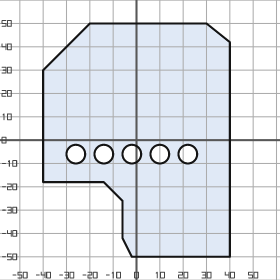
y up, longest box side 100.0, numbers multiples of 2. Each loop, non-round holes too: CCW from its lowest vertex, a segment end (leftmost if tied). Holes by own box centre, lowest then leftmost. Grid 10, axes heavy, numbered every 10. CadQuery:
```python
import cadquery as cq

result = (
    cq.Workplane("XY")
    .moveTo(-2.0, -50.0)
    .lineTo(40.0, -50.0)
    .lineTo(40.0, 42.0)
    .lineTo(30.0, 50.0)
    .lineTo(-20.0, 50.0)
    .lineTo(-40.0, 30.0)
    .lineTo(-40.0, -18.0)
    .lineTo(-14.0, -18.0)
    .lineTo(-6.0, -26.0)
    .lineTo(-6.0, -42.0)
    .close()
    .moveTo(-26.0, -6.0)
    .circle(4.0)
    .moveTo(-14.0, -6.0)
    .circle(4.0)
    .moveTo(-2.0, -6.0)
    .circle(4.0)
    .moveTo(10.0, -6.0)
    .circle(4.0)
    .moveTo(22.0, -6.0)
    .circle(4.0)
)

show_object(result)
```